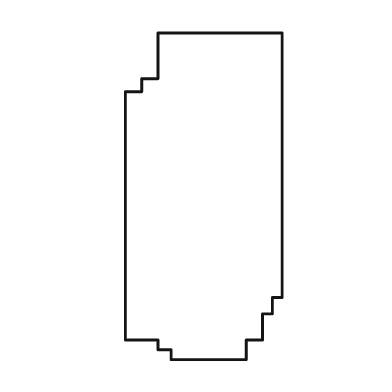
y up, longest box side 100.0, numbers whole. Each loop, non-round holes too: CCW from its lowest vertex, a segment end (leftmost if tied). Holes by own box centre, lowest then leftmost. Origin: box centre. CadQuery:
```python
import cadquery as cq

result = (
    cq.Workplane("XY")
    .moveTo(-10.0, -50.0)
    .lineTo(13.0, -50.0)
    .lineTo(13.0, -44.0)
    .lineTo(18.0, -44.0)
    .lineTo(18.0, -36.0)
    .lineTo(21.0, -36.0)
    .lineTo(21.0, -31.0)
    .lineTo(24.0, -31.0)
    .lineTo(24.0, 50.0)
    .lineTo(-14.0, 50.0)
    .lineTo(-14.0, 36.0)
    .lineTo(-19.0, 36.0)
    .lineTo(-19.0, 32.0)
    .lineTo(-24.0, 32.0)
    .lineTo(-24.0, -44.0)
    .lineTo(-14.0, -44.0)
    .lineTo(-14.0, -47.0)
    .lineTo(-10.0, -47.0)
    .close()
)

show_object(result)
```